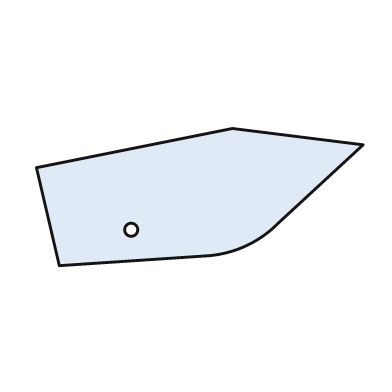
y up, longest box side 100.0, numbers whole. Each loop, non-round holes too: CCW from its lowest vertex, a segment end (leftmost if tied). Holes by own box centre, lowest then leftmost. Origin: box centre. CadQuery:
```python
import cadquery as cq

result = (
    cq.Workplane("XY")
    .moveTo(-43.0, -21.0)
    .lineTo(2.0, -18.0)
    .threePointArc((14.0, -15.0), (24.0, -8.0))
    .lineTo(50.0, 16.0)
    .lineTo(10.0, 21.0)
    .lineTo(-50.0, 9.0)
    .close()
    .moveTo(-21.0, -10.0)
    .circle(2.0)
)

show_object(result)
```